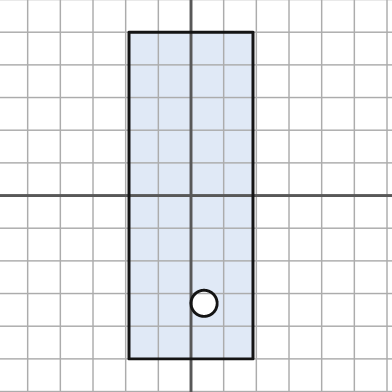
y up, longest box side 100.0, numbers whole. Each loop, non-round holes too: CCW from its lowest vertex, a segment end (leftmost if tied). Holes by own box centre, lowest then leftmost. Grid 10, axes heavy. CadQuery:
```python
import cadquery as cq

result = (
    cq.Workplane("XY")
    .moveTo(-19.0, -50.0)
    .lineTo(19.0, -50.0)
    .lineTo(19.0, 50.0)
    .lineTo(-19.0, 50.0)
    .close()
    .moveTo(4.0, -33.0)
    .circle(4.0)
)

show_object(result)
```